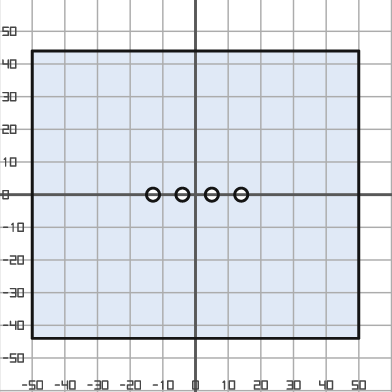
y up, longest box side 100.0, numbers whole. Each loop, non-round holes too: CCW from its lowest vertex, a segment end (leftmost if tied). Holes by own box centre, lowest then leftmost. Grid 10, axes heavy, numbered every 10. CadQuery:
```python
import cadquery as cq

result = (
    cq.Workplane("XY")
    .moveTo(-50.0, -44.0)
    .lineTo(50.0, -44.0)
    .lineTo(50.0, 44.0)
    .lineTo(-50.0, 44.0)
    .close()
    .moveTo(-13.0, 0.0)
    .circle(2.0)
    .moveTo(-4.0, 0.0)
    .circle(2.0)
    .moveTo(5.0, 0.0)
    .circle(2.0)
    .moveTo(14.0, 0.0)
    .circle(2.0)
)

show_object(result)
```